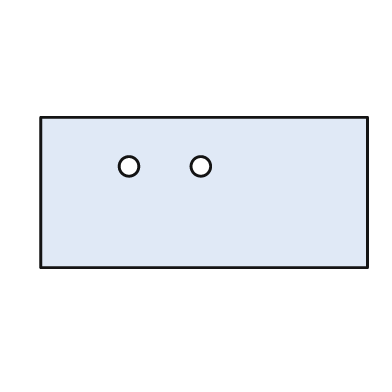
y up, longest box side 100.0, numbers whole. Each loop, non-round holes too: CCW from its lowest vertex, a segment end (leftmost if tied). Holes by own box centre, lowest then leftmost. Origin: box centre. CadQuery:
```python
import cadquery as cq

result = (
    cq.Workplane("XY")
    .moveTo(-50.0, -23.0)
    .lineTo(50.0, -23.0)
    .lineTo(50.0, 23.0)
    .lineTo(-50.0, 23.0)
    .close()
    .moveTo(-23.0, 8.0)
    .circle(3.0)
    .moveTo(-1.0, 8.0)
    .circle(3.0)
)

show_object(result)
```